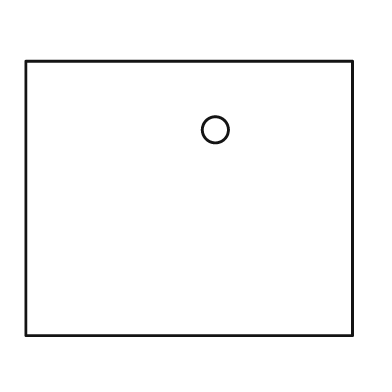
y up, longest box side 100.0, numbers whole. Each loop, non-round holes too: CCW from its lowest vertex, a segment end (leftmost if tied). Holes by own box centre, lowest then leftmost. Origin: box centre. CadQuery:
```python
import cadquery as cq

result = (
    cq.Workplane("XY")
    .moveTo(-50.0, -42.0)
    .lineTo(50.0, -42.0)
    .lineTo(50.0, 42.0)
    .lineTo(-50.0, 42.0)
    .close()
    .moveTo(8.0, 21.0)
    .circle(4.0)
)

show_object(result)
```